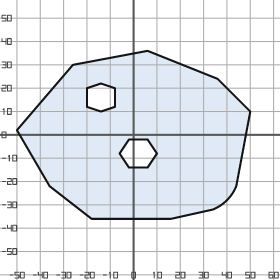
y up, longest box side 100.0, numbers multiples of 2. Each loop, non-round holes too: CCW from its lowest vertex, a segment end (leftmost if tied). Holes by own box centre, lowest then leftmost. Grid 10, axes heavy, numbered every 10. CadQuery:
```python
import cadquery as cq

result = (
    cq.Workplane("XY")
    .moveTo(-18.0, -36.0)
    .lineTo(16.0, -36.0)
    .lineTo(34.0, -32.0)
    .threePointArc((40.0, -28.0), (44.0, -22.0))
    .lineTo(50.0, 10.0)
    .lineTo(36.0, 24.0)
    .lineTo(6.0, 36.0)
    .lineTo(-26.0, 30.0)
    .lineTo(-50.0, 2.0)
    .lineTo(-36.0, -22.0)
    .close()
    .moveTo(-2.0, -14.0)
    .lineTo(6.0, -14.0)
    .lineTo(10.0, -8.0)
    .lineTo(6.0, -2.0)
    .lineTo(-2.0, -2.0)
    .lineTo(-6.0, -8.0)
    .close()
    .moveTo(-14.0, 10.0)
    .lineTo(-8.0, 12.0)
    .lineTo(-8.0, 20.0)
    .lineTo(-14.0, 22.0)
    .lineTo(-20.0, 20.0)
    .lineTo(-20.0, 12.0)
    .close()
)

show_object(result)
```